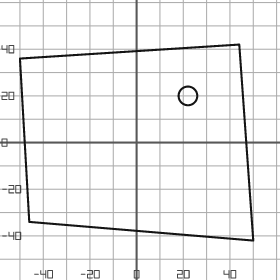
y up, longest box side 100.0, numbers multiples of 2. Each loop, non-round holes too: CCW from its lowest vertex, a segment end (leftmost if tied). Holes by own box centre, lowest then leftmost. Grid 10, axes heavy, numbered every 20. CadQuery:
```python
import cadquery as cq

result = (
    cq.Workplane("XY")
    .moveTo(50.0, -42.0)
    .lineTo(44.0, 42.0)
    .lineTo(-50.0, 36.0)
    .lineTo(-46.0, -34.0)
    .close()
    .moveTo(22.0, 20.0)
    .circle(4.0)
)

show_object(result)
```